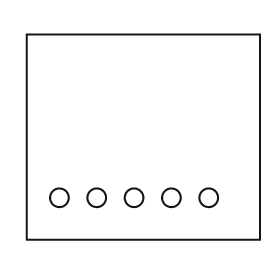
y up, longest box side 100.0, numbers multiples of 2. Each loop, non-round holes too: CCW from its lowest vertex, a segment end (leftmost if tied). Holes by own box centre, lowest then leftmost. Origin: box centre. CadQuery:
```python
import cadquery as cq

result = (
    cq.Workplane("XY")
    .moveTo(-50.0, -44.0)
    .lineTo(50.0, -44.0)
    .lineTo(50.0, 44.0)
    .lineTo(-50.0, 44.0)
    .close()
    .moveTo(-36.0, -26.0)
    .circle(4.0)
    .moveTo(-20.0, -26.0)
    .circle(4.0)
    .moveTo(-4.0, -26.0)
    .circle(4.0)
    .moveTo(12.0, -26.0)
    .circle(4.0)
    .moveTo(28.0, -26.0)
    .circle(4.0)
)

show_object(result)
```